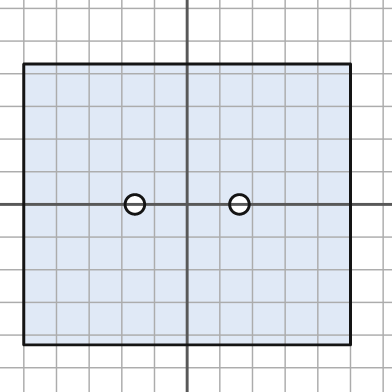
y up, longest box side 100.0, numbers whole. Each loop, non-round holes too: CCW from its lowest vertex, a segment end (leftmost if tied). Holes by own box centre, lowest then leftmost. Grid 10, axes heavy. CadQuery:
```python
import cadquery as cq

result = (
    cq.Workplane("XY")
    .moveTo(-50.0, -43.0)
    .lineTo(50.0, -43.0)
    .lineTo(50.0, 43.0)
    .lineTo(-50.0, 43.0)
    .close()
    .moveTo(-16.0, 0.0)
    .circle(3.0)
    .moveTo(16.0, 0.0)
    .circle(3.0)
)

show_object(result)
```